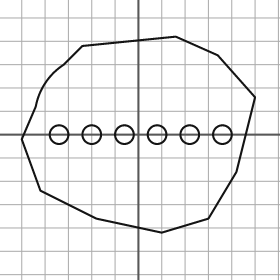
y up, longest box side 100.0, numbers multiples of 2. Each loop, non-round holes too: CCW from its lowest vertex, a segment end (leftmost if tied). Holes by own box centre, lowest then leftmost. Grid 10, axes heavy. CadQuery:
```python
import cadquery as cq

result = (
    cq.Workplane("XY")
    .moveTo(10.0, -42.0)
    .lineTo(30.0, -36.0)
    .lineTo(42.0, -16.0)
    .lineTo(50.0, 16.0)
    .lineTo(34.0, 34.0)
    .lineTo(16.0, 42.0)
    .lineTo(-24.0, 38.0)
    .lineTo(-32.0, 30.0)
    .threePointArc((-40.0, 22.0), (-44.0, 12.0))
    .lineTo(-50.0, -2.0)
    .lineTo(-42.0, -24.0)
    .lineTo(-18.0, -36.0)
    .close()
    .moveTo(-34.0, 0.0)
    .circle(4.0)
    .moveTo(-20.0, 0.0)
    .circle(4.0)
    .moveTo(-6.0, 0.0)
    .circle(4.0)
    .moveTo(8.0, 0.0)
    .circle(4.0)
    .moveTo(22.0, 0.0)
    .circle(4.0)
    .moveTo(36.0, 0.0)
    .circle(4.0)
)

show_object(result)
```